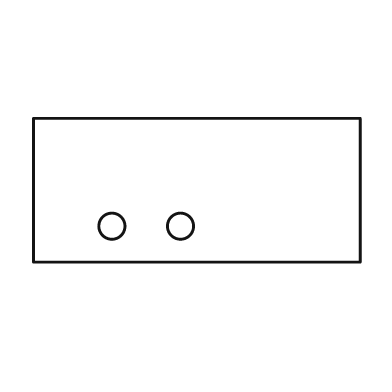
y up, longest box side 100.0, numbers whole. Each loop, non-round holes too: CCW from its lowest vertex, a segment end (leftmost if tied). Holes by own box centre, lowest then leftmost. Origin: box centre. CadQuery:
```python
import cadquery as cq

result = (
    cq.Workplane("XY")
    .moveTo(-50.0, -22.0)
    .lineTo(50.0, -22.0)
    .lineTo(50.0, 22.0)
    .lineTo(-50.0, 22.0)
    .close()
    .moveTo(-26.0, -11.0)
    .circle(4.0)
    .moveTo(-5.0, -11.0)
    .circle(4.0)
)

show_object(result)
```